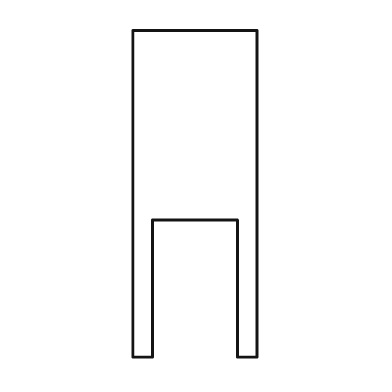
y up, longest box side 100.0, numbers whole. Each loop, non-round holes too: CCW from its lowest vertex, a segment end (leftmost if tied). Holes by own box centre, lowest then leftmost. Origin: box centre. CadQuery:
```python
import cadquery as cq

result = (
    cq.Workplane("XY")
    .moveTo(-19.0, -50.0)
    .lineTo(-13.0, -50.0)
    .lineTo(-13.0, -8.0)
    .lineTo(13.0, -8.0)
    .lineTo(13.0, -50.0)
    .lineTo(19.0, -50.0)
    .lineTo(19.0, 50.0)
    .lineTo(-19.0, 50.0)
    .close()
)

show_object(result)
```